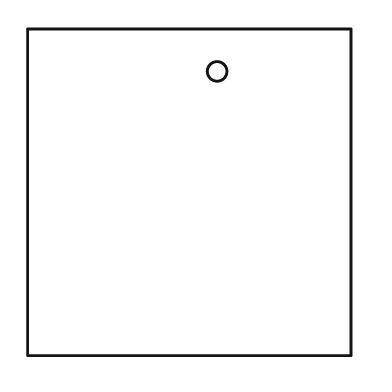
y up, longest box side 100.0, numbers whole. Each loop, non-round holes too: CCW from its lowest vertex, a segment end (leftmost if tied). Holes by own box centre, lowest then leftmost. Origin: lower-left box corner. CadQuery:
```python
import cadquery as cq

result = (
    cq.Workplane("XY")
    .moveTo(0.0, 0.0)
    .lineTo(99.0, 0.0)
    .lineTo(99.0, 100.0)
    .lineTo(0.0, 100.0)
    .close()
    .moveTo(58.0, 87.0)
    .circle(3.0)
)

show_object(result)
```